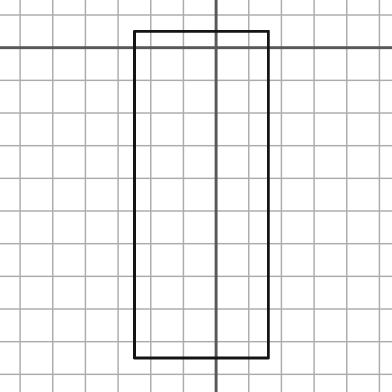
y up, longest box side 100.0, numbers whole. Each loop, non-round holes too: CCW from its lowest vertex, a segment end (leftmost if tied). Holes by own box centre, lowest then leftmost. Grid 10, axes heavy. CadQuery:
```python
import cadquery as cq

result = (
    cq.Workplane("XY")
    .moveTo(-25.0, -95.0)
    .lineTo(16.0, -95.0)
    .lineTo(16.0, 5.0)
    .lineTo(-25.0, 5.0)
    .close()
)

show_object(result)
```